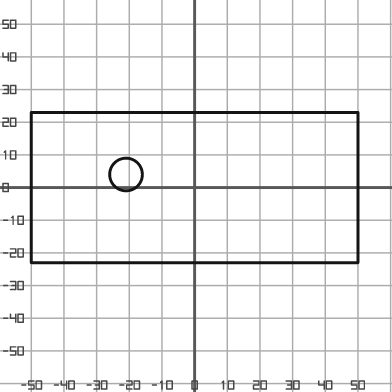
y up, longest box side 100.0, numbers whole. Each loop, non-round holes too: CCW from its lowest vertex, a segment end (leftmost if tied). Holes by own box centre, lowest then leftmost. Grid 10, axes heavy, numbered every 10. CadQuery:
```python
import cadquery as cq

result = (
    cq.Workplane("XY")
    .moveTo(-50.0, -23.0)
    .lineTo(50.0, -23.0)
    .lineTo(50.0, 23.0)
    .lineTo(-50.0, 23.0)
    .close()
    .moveTo(-21.0, 4.0)
    .circle(5.0)
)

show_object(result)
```